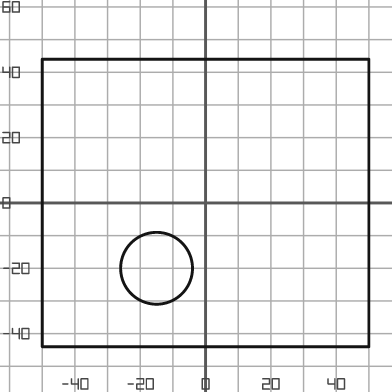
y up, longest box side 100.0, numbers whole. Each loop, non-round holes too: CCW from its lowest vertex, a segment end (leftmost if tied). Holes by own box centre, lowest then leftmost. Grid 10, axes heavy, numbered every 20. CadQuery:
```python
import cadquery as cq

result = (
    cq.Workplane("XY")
    .moveTo(-50.0, -44.0)
    .lineTo(50.0, -44.0)
    .lineTo(50.0, 44.0)
    .lineTo(-50.0, 44.0)
    .close()
    .moveTo(-15.0, -20.0)
    .circle(11.0)
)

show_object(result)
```